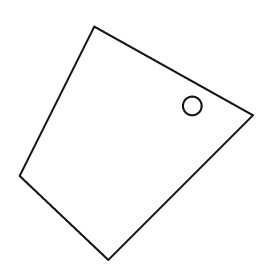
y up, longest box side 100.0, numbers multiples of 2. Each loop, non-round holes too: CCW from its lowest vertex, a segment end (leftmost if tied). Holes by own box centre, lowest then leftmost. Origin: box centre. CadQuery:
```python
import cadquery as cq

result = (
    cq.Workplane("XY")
    .moveTo(-12.0, -50.0)
    .lineTo(50.0, 12.0)
    .lineTo(-18.0, 50.0)
    .lineTo(-50.0, -14.0)
    .close()
    .moveTo(24.0, 16.0)
    .circle(4.0)
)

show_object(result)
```